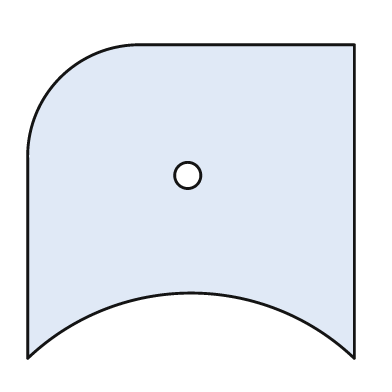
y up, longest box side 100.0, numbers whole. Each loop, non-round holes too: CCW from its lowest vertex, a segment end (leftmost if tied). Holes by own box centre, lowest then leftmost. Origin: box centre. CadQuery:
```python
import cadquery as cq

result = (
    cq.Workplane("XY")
    .moveTo(-50.0, -48.0)
    .threePointArc((0.0, -28.0), (50.0, -48.0))
    .lineTo(50.0, 48.0)
    .lineTo(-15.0, 48.0)
    .threePointArc((-40.0, 38.0), (-50.0, 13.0))
    .close()
    .moveTo(-1.0, 8.0)
    .circle(4.0)
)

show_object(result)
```